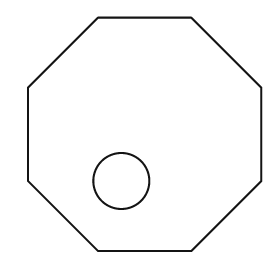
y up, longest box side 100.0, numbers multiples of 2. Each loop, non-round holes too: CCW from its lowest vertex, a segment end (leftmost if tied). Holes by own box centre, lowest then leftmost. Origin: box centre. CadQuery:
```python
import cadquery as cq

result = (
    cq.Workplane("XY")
    .moveTo(-20.0, -50.0)
    .lineTo(20.0, -50.0)
    .lineTo(50.0, -20.0)
    .lineTo(50.0, 20.0)
    .lineTo(20.0, 50.0)
    .lineTo(-20.0, 50.0)
    .lineTo(-50.0, 20.0)
    .lineTo(-50.0, -20.0)
    .close()
    .moveTo(-10.0, -20.0)
    .circle(12.0)
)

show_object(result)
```